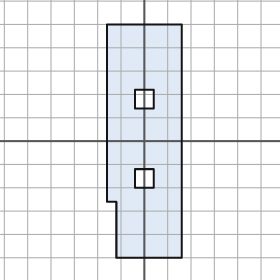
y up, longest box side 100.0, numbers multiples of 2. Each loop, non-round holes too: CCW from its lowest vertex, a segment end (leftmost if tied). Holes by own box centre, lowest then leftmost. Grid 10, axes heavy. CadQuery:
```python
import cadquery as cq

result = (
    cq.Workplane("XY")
    .moveTo(-12.0, -50.0)
    .lineTo(16.0, -50.0)
    .lineTo(16.0, 50.0)
    .lineTo(-16.0, 50.0)
    .lineTo(-16.0, -26.0)
    .lineTo(-12.0, -26.0)
    .close()
    .moveTo(-4.0, -20.0)
    .lineTo(4.0, -20.0)
    .lineTo(4.0, -12.0)
    .lineTo(-4.0, -12.0)
    .close()
    .moveTo(-4.0, 14.0)
    .lineTo(4.0, 14.0)
    .lineTo(4.0, 22.0)
    .lineTo(-4.0, 22.0)
    .close()
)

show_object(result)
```